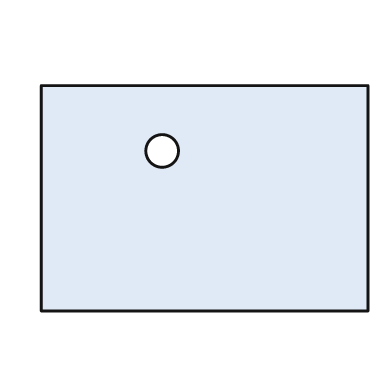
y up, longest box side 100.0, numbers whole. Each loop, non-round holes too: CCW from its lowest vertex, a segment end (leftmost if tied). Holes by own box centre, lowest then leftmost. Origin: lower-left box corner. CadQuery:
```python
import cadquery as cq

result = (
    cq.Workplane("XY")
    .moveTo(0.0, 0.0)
    .lineTo(100.0, 0.0)
    .lineTo(100.0, 69.0)
    .lineTo(0.0, 69.0)
    .close()
    .moveTo(37.0, 49.0)
    .circle(5.0)
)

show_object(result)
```